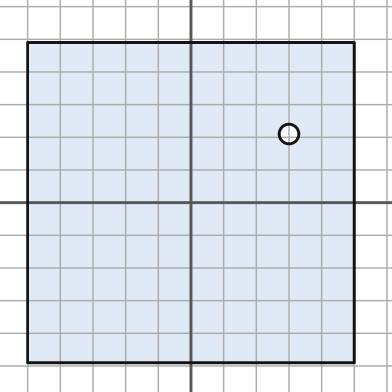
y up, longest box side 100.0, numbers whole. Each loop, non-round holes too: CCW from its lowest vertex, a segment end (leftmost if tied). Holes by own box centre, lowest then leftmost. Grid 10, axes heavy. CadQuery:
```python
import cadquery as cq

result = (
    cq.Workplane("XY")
    .moveTo(-50.0, -49.0)
    .lineTo(50.0, -49.0)
    .lineTo(50.0, 49.0)
    .lineTo(-50.0, 49.0)
    .close()
    .moveTo(30.0, 21.0)
    .circle(3.0)
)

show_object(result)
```